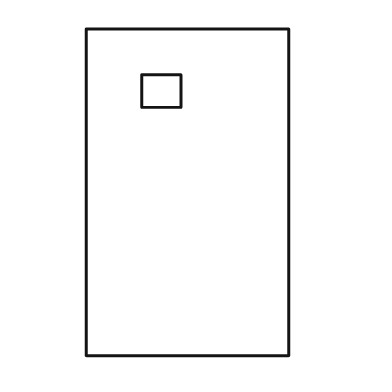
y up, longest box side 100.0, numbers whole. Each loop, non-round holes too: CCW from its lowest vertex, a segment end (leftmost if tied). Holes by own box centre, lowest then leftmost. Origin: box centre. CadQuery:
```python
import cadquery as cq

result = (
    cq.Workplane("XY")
    .moveTo(-31.0, -50.0)
    .lineTo(31.0, -50.0)
    .lineTo(31.0, 50.0)
    .lineTo(-31.0, 50.0)
    .close()
    .moveTo(-14.0, 26.0)
    .lineTo(-2.0, 26.0)
    .lineTo(-2.0, 36.0)
    .lineTo(-14.0, 36.0)
    .close()
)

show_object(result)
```